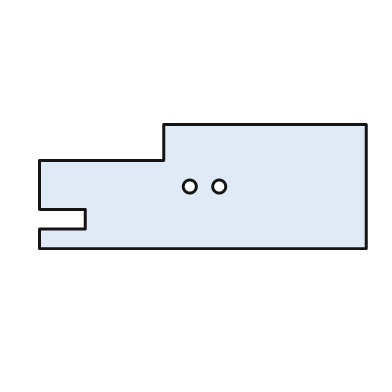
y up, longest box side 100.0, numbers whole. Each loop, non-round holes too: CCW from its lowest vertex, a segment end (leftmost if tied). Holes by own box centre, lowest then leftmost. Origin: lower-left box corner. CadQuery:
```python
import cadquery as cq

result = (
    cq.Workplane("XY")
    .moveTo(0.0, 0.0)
    .lineTo(100.0, 0.0)
    .lineTo(100.0, 38.0)
    .lineTo(38.0, 38.0)
    .lineTo(38.0, 27.0)
    .lineTo(0.0, 27.0)
    .lineTo(0.0, 12.0)
    .lineTo(14.0, 12.0)
    .lineTo(14.0, 6.0)
    .lineTo(0.0, 6.0)
    .close()
    .moveTo(46.0, 19.0)
    .circle(2.0)
    .moveTo(55.0, 19.0)
    .circle(2.0)
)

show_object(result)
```